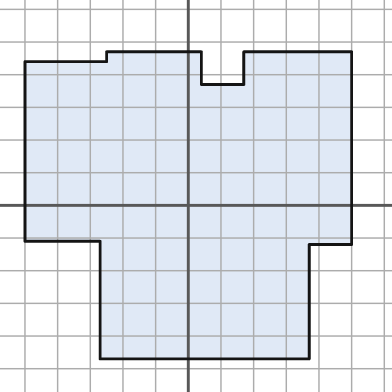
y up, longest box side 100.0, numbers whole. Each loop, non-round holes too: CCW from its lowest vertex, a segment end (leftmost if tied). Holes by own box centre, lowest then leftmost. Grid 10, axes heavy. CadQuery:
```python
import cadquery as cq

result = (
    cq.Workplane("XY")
    .moveTo(-27.0, -47.0)
    .lineTo(37.0, -47.0)
    .lineTo(37.0, -12.0)
    .lineTo(50.0, -12.0)
    .lineTo(50.0, 47.0)
    .lineTo(17.0, 47.0)
    .lineTo(17.0, 37.0)
    .lineTo(4.0, 37.0)
    .lineTo(4.0, 47.0)
    .lineTo(-25.0, 47.0)
    .lineTo(-25.0, 44.0)
    .lineTo(-50.0, 44.0)
    .lineTo(-50.0, -11.0)
    .lineTo(-27.0, -11.0)
    .close()
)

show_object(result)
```